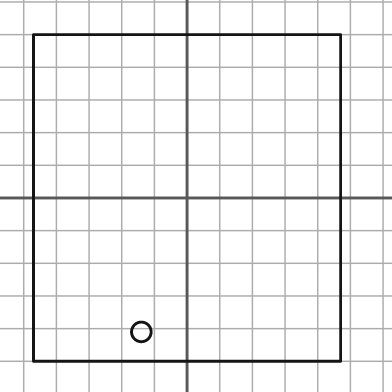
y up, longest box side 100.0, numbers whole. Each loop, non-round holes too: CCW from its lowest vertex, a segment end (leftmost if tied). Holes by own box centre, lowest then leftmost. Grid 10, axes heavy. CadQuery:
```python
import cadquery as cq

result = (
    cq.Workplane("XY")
    .moveTo(-47.0, -50.0)
    .lineTo(47.0, -50.0)
    .lineTo(47.0, 50.0)
    .lineTo(-47.0, 50.0)
    .close()
    .moveTo(-14.0, -41.0)
    .circle(3.0)
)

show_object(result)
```